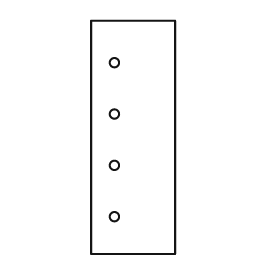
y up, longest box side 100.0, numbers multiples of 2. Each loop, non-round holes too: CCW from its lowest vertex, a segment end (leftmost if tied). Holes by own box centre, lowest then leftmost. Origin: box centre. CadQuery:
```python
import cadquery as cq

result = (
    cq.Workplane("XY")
    .moveTo(-18.0, -50.0)
    .lineTo(18.0, -50.0)
    .lineTo(18.0, 50.0)
    .lineTo(-18.0, 50.0)
    .close()
    .moveTo(-8.0, -34.0)
    .circle(2.0)
    .moveTo(-8.0, -12.0)
    .circle(2.0)
    .moveTo(-8.0, 10.0)
    .circle(2.0)
    .moveTo(-8.0, 32.0)
    .circle(2.0)
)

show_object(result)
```